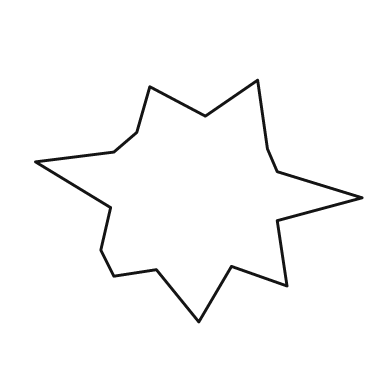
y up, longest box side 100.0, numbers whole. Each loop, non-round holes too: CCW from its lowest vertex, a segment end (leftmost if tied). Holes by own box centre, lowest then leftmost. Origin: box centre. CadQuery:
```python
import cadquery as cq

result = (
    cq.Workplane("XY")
    .moveTo(0.0, -37.0)
    .lineTo(10.0, -20.0)
    .lineTo(27.0, -26.0)
    .lineTo(24.0, -6.0)
    .lineTo(50.0, 1.0)
    .lineTo(24.0, 9.0)
    .lineTo(21.0, 16.0)
    .lineTo(18.0, 37.0)
    .lineTo(2.0, 26.0)
    .lineTo(-15.0, 35.0)
    .lineTo(-19.0, 21.0)
    .lineTo(-26.0, 15.0)
    .lineTo(-50.0, 12.0)
    .lineTo(-27.0, -2.0)
    .lineTo(-30.0, -15.0)
    .lineTo(-26.0, -23.0)
    .lineTo(-13.0, -21.0)
    .close()
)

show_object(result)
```